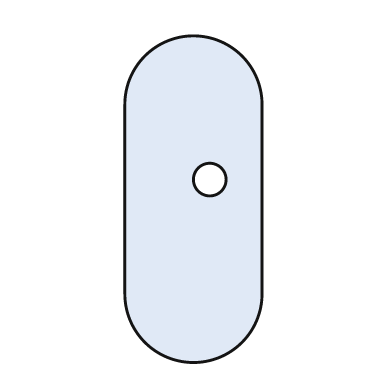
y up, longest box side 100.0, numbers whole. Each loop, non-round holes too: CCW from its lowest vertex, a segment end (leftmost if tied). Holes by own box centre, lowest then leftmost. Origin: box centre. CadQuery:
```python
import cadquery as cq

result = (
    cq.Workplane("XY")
    .moveTo(-21.0, -29.0)
    .threePointArc((0.0, -50.0), (21.0, -29.0))
    .lineTo(21.0, 29.0)
    .threePointArc((0.0, 50.0), (-21.0, 29.0))
    .close()
    .moveTo(5.0, 6.0)
    .circle(5.0)
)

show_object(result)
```